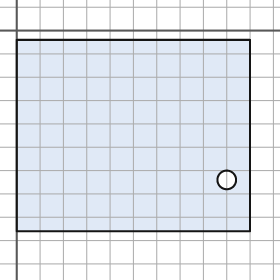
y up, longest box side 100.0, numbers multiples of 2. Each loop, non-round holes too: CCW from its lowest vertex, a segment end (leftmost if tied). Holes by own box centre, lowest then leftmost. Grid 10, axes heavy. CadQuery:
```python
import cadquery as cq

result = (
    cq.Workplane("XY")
    .moveTo(0.0, -86.0)
    .lineTo(100.0, -86.0)
    .lineTo(100.0, -4.0)
    .lineTo(0.0, -4.0)
    .close()
    .moveTo(90.0, -64.0)
    .circle(4.0)
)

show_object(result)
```